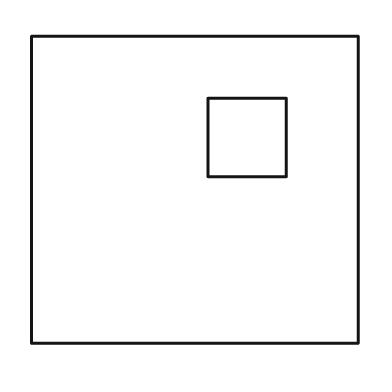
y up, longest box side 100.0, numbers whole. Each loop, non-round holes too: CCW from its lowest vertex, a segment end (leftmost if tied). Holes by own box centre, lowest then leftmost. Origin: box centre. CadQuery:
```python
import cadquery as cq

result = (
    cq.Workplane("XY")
    .moveTo(-50.0, -47.0)
    .lineTo(50.0, -47.0)
    .lineTo(50.0, 47.0)
    .lineTo(-50.0, 47.0)
    .close()
    .moveTo(4.0, 4.0)
    .lineTo(28.0, 4.0)
    .lineTo(28.0, 28.0)
    .lineTo(4.0, 28.0)
    .close()
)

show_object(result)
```